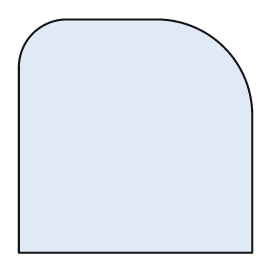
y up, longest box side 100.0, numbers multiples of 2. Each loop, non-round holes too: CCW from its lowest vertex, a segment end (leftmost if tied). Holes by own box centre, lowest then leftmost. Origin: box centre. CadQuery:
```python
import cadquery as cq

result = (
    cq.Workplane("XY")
    .moveTo(-50.0, -50.0)
    .lineTo(50.0, -50.0)
    .lineTo(50.0, 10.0)
    .threePointArc((38.0, 38.0), (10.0, 50.0))
    .lineTo(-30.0, 50.0)
    .threePointArc((-44.0, 44.0), (-50.0, 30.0))
    .close()
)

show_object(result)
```